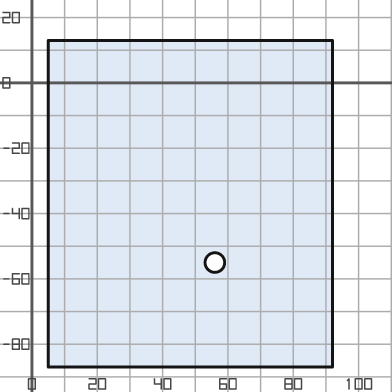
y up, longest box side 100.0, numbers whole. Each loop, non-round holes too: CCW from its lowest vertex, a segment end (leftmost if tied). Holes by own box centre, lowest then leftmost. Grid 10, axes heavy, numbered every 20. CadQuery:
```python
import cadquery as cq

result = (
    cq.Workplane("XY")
    .moveTo(5.0, -87.0)
    .lineTo(92.0, -87.0)
    .lineTo(92.0, 13.0)
    .lineTo(5.0, 13.0)
    .close()
    .moveTo(56.0, -55.0)
    .circle(3.0)
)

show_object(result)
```